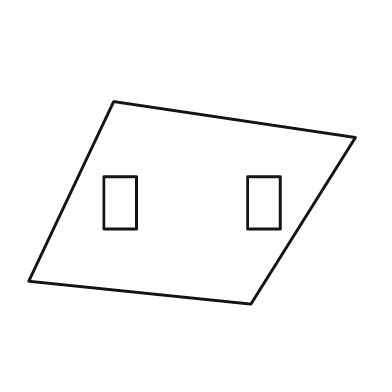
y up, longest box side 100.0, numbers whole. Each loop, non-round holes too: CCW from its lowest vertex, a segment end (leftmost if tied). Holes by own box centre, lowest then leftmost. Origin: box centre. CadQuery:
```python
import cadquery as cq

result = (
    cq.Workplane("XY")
    .moveTo(18.0, -31.0)
    .lineTo(50.0, 20.0)
    .lineTo(-24.0, 31.0)
    .lineTo(-50.0, -24.0)
    .close()
    .moveTo(-27.0, -8.0)
    .lineTo(-17.0, -8.0)
    .lineTo(-17.0, 8.0)
    .lineTo(-27.0, 8.0)
    .close()
    .moveTo(17.0, -8.0)
    .lineTo(27.0, -8.0)
    .lineTo(27.0, 8.0)
    .lineTo(17.0, 8.0)
    .close()
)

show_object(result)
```